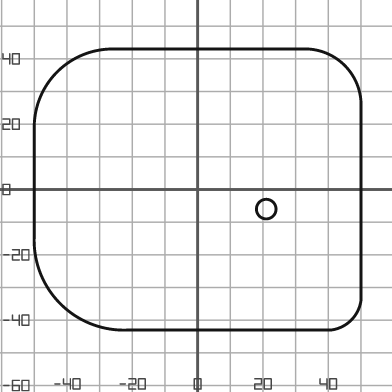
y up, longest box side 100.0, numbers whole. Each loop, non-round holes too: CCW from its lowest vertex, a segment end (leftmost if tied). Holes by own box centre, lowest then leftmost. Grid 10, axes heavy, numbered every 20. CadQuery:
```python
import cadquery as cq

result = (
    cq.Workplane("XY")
    .moveTo(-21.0, -43.0)
    .lineTo(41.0, -43.0)
    .threePointArc((47.0, -40.0), (50.0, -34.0))
    .lineTo(50.0, 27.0)
    .threePointArc((45.0, 38.0), (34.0, 43.0))
    .lineTo(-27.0, 43.0)
    .threePointArc((-43.0, 36.0), (-50.0, 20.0))
    .lineTo(-50.0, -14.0)
    .threePointArc((-42.0, -35.0), (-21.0, -43.0))
    .close()
    .moveTo(21.0, -6.0)
    .circle(3.0)
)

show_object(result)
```